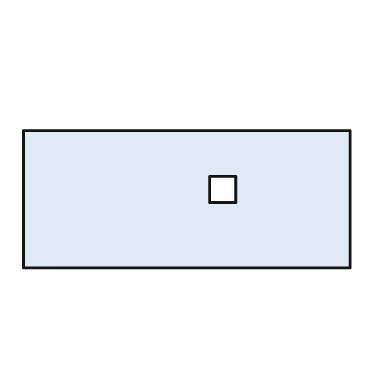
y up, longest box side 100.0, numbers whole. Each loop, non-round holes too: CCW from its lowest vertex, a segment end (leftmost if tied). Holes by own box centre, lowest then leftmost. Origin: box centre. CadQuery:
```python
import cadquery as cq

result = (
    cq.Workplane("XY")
    .moveTo(-50.0, -21.0)
    .lineTo(50.0, -21.0)
    .lineTo(50.0, 21.0)
    .lineTo(-50.0, 21.0)
    .close()
    .moveTo(7.0, -1.0)
    .lineTo(15.0, -1.0)
    .lineTo(15.0, 7.0)
    .lineTo(7.0, 7.0)
    .close()
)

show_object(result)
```